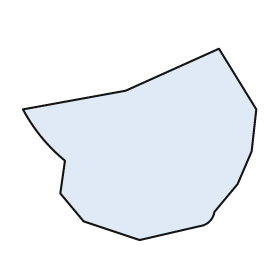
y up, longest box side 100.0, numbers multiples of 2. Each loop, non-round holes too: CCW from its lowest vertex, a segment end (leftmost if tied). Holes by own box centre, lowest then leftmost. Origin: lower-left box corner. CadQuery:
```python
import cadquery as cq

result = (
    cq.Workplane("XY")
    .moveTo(50.0, 0.0)
    .lineTo(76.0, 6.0)
    .threePointArc((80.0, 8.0), (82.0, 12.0))
    .lineTo(92.0, 24.0)
    .lineTo(98.0, 38.0)
    .lineTo(100.0, 56.0)
    .lineTo(84.0, 82.0)
    .lineTo(44.0, 64.0)
    .lineTo(0.0, 56.0)
    .threePointArc((8.0, 44.0), (18.0, 34.0))
    .lineTo(16.0, 20.0)
    .lineTo(26.0, 8.0)
    .close()
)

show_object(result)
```